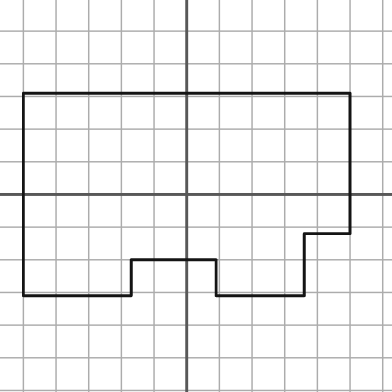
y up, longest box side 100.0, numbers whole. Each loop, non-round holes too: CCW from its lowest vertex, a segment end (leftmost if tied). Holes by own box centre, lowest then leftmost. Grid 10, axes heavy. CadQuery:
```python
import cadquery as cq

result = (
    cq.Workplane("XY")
    .moveTo(-50.0, -31.0)
    .lineTo(-17.0, -31.0)
    .lineTo(-17.0, -20.0)
    .lineTo(9.0, -20.0)
    .lineTo(9.0, -31.0)
    .lineTo(36.0, -31.0)
    .lineTo(36.0, -12.0)
    .lineTo(50.0, -12.0)
    .lineTo(50.0, 31.0)
    .lineTo(-50.0, 31.0)
    .close()
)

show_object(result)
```